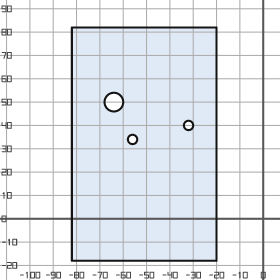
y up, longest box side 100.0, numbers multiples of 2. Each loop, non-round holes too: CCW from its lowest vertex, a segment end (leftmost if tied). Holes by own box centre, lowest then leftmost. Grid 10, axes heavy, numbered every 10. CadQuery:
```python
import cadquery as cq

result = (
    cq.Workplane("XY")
    .moveTo(-82.0, -18.0)
    .lineTo(-20.0, -18.0)
    .lineTo(-20.0, 82.0)
    .lineTo(-82.0, 82.0)
    .close()
    .moveTo(-56.0, 34.0)
    .circle(2.0)
    .moveTo(-32.0, 40.0)
    .circle(2.0)
    .moveTo(-64.0, 50.0)
    .circle(4.0)
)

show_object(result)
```